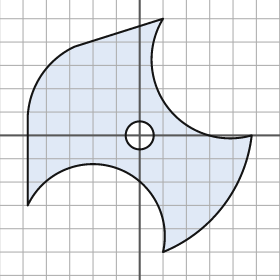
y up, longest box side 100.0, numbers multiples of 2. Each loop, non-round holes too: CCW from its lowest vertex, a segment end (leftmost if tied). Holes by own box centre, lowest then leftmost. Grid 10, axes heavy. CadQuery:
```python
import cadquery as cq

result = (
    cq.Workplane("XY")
    .moveTo(10.0, -50.0)
    .threePointArc((36.0, -30.0), (48.0, 0.0))
    .threePointArc((12.0, 12.0), (10.0, 50.0))
    .lineTo(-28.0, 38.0)
    .threePointArc((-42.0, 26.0), (-48.0, 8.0))
    .lineTo(-48.0, -30.0)
    .threePointArc((-10.0, -14.0), (10.0, -50.0))
    .close()
    .moveTo(0.0, 0.0)
    .circle(6.0)
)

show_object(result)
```